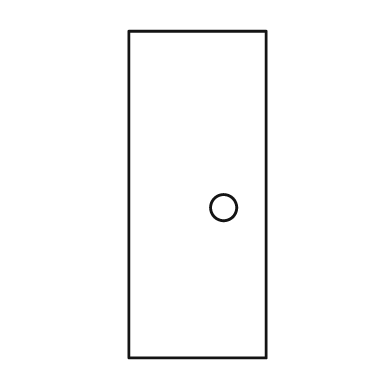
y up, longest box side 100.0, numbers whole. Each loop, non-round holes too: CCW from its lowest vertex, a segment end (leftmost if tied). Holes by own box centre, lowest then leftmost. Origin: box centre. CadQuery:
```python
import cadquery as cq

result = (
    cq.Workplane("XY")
    .moveTo(-21.0, -50.0)
    .lineTo(21.0, -50.0)
    .lineTo(21.0, 50.0)
    .lineTo(-21.0, 50.0)
    .close()
    .moveTo(8.0, -4.0)
    .circle(4.0)
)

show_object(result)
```